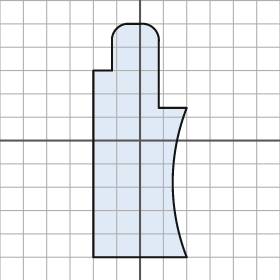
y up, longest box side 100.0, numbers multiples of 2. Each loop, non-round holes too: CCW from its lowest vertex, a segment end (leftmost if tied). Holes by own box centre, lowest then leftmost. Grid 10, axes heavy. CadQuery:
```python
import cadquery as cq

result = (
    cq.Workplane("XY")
    .moveTo(-20.0, -50.0)
    .lineTo(20.0, -50.0)
    .threePointArc((14.0, -18.0), (20.0, 14.0))
    .lineTo(8.0, 14.0)
    .lineTo(8.0, 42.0)
    .threePointArc((6.0, 48.0), (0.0, 50.0))
    .lineTo(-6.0, 50.0)
    .threePointArc((-10.0, 48.0), (-12.0, 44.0))
    .lineTo(-12.0, 30.0)
    .lineTo(-20.0, 30.0)
    .close()
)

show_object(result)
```